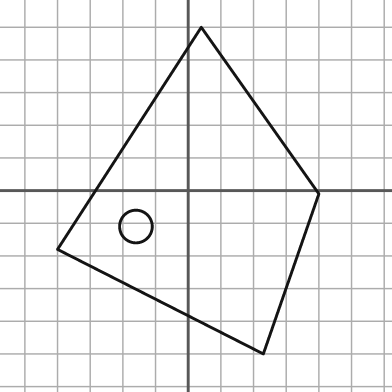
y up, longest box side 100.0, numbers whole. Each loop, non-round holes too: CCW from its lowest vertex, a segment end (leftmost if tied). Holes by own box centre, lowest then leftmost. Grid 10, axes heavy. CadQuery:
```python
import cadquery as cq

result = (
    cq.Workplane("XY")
    .moveTo(23.0, -50.0)
    .lineTo(40.0, -1.0)
    .lineTo(4.0, 50.0)
    .lineTo(-40.0, -18.0)
    .close()
    .moveTo(-16.0, -11.0)
    .circle(5.0)
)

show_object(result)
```